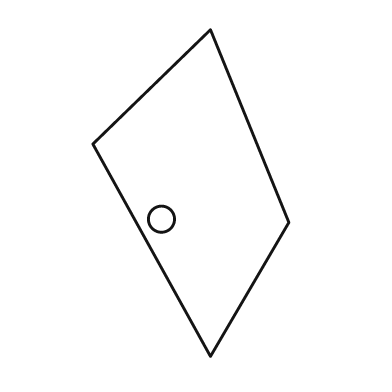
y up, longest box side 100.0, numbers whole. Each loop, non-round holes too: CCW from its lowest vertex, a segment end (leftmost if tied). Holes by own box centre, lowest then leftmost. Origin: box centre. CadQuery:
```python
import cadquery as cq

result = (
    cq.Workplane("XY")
    .moveTo(6.0, -50.0)
    .lineTo(30.0, -9.0)
    .lineTo(6.0, 50.0)
    .lineTo(-30.0, 15.0)
    .close()
    .moveTo(-9.0, -8.0)
    .circle(4.0)
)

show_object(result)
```